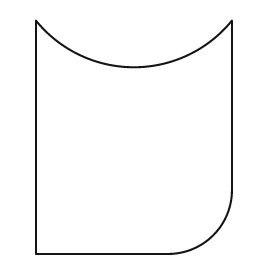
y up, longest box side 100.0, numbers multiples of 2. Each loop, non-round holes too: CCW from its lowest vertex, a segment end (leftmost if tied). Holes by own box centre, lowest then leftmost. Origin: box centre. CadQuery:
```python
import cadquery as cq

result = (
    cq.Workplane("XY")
    .moveTo(-42.0, -50.0)
    .lineTo(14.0, -50.0)
    .threePointArc((34.0, -42.0), (42.0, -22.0))
    .lineTo(42.0, 50.0)
    .threePointArc((0.0, 30.0), (-42.0, 50.0))
    .close()
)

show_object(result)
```